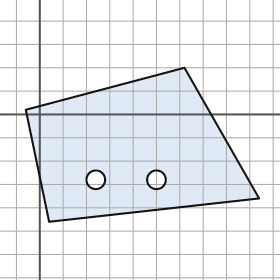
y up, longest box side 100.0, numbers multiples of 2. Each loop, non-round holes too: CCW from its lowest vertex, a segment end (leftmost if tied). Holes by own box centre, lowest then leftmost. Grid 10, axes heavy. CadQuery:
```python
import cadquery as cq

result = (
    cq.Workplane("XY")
    .moveTo(4.0, -46.0)
    .lineTo(94.0, -36.0)
    .lineTo(62.0, 20.0)
    .lineTo(-6.0, 2.0)
    .close()
    .moveTo(24.0, -28.0)
    .circle(4.0)
    .moveTo(50.0, -28.0)
    .circle(4.0)
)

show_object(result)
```